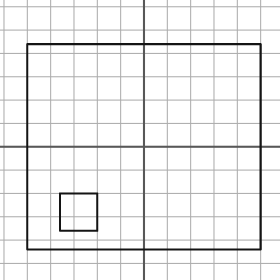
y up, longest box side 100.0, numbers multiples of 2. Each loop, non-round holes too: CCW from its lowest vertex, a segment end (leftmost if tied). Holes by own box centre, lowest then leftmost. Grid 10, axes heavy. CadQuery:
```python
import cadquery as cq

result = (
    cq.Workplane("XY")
    .moveTo(-50.0, -44.0)
    .lineTo(50.0, -44.0)
    .lineTo(50.0, 44.0)
    .lineTo(-50.0, 44.0)
    .close()
    .moveTo(-36.0, -36.0)
    .lineTo(-20.0, -36.0)
    .lineTo(-20.0, -20.0)
    .lineTo(-36.0, -20.0)
    .close()
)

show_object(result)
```